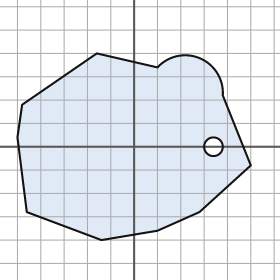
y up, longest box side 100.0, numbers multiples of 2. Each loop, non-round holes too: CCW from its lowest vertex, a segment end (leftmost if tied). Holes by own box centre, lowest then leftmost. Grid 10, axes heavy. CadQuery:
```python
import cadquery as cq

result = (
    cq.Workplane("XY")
    .moveTo(-14.0, -40.0)
    .lineTo(10.0, -36.0)
    .lineTo(28.0, -28.0)
    .lineTo(50.0, -8.0)
    .lineTo(38.0, 22.0)
    .threePointArc((28.0, 38.0), (10.0, 34.0))
    .lineTo(-16.0, 40.0)
    .lineTo(-48.0, 18.0)
    .lineTo(-50.0, 4.0)
    .lineTo(-46.0, -28.0)
    .close()
    .moveTo(34.0, 0.0)
    .circle(4.0)
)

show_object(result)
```